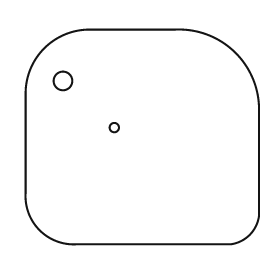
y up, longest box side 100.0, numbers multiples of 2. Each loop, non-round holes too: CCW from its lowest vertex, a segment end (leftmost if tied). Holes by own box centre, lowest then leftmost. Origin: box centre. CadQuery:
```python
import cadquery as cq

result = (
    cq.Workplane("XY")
    .moveTo(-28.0, -46.0)
    .lineTo(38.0, -46.0)
    .threePointArc((46.0, -42.0), (50.0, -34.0))
    .lineTo(50.0, 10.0)
    .threePointArc((40.0, 36.0), (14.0, 46.0))
    .lineTo(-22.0, 46.0)
    .threePointArc((-42.0, 38.0), (-50.0, 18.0))
    .lineTo(-50.0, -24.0)
    .threePointArc((-44.0, -40.0), (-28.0, -46.0))
    .close()
    .moveTo(-12.0, 4.0)
    .circle(2.0)
    .moveTo(-34.0, 24.0)
    .circle(4.0)
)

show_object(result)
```